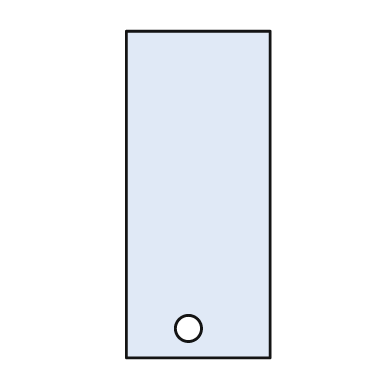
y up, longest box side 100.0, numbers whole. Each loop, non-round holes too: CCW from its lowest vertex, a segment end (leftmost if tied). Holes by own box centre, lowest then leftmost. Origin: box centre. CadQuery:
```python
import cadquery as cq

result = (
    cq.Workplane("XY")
    .moveTo(-22.0, -50.0)
    .lineTo(22.0, -50.0)
    .lineTo(22.0, 50.0)
    .lineTo(-22.0, 50.0)
    .close()
    .moveTo(-3.0, -41.0)
    .circle(4.0)
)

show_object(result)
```